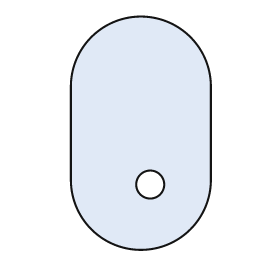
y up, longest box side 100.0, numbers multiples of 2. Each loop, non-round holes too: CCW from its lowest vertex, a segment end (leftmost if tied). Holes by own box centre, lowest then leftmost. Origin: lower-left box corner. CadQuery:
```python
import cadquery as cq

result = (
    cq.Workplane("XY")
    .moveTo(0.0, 30.0)
    .threePointArc((30.0, 0.0), (60.0, 30.0))
    .lineTo(60.0, 70.0)
    .threePointArc((30.0, 100.0), (0.0, 70.0))
    .close()
    .moveTo(34.0, 28.0)
    .circle(6.0)
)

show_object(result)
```